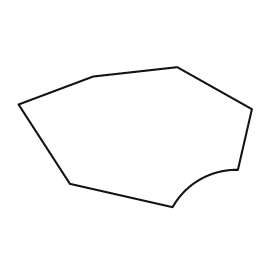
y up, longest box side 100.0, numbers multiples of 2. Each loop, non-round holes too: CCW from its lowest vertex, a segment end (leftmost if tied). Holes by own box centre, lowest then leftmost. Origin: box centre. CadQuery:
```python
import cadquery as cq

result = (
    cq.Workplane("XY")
    .moveTo(16.0, -30.0)
    .threePointArc((28.0, -18.0), (44.0, -14.0))
    .lineTo(50.0, 12.0)
    .lineTo(18.0, 30.0)
    .lineTo(-18.0, 26.0)
    .lineTo(-50.0, 14.0)
    .lineTo(-28.0, -20.0)
    .close()
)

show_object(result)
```